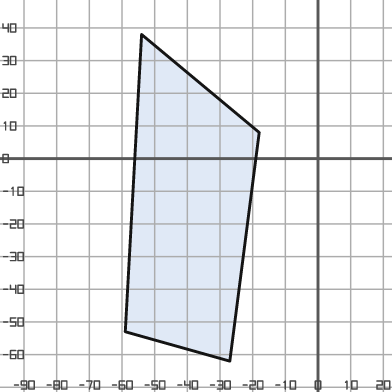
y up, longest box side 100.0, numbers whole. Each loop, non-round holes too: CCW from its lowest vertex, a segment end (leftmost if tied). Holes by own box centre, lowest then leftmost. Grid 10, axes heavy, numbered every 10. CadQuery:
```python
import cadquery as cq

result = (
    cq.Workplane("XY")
    .moveTo(-27.0, -62.0)
    .lineTo(-18.0, 8.0)
    .lineTo(-54.0, 38.0)
    .lineTo(-59.0, -53.0)
    .close()
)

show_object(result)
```